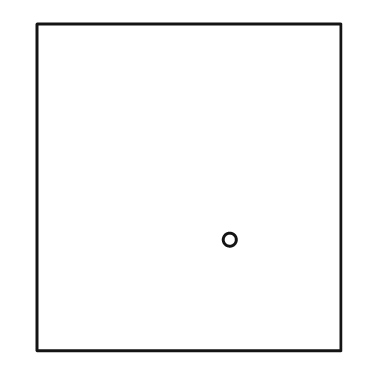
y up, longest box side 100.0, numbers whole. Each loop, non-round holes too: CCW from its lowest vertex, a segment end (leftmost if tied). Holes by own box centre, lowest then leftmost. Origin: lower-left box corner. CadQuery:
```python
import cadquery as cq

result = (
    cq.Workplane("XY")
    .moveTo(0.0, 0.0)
    .lineTo(93.0, 0.0)
    .lineTo(93.0, 100.0)
    .lineTo(0.0, 100.0)
    .close()
    .moveTo(59.0, 34.0)
    .circle(2.0)
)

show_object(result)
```